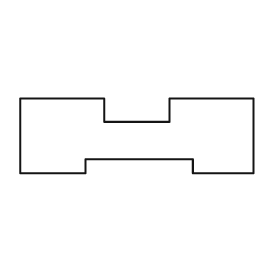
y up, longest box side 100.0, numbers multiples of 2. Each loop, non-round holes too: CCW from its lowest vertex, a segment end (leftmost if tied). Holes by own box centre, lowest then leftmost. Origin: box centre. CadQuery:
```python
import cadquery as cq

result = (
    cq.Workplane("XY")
    .moveTo(-50.0, -16.0)
    .lineTo(-22.0, -16.0)
    .lineTo(-22.0, -10.0)
    .lineTo(24.0, -10.0)
    .lineTo(24.0, -16.0)
    .lineTo(50.0, -16.0)
    .lineTo(50.0, 16.0)
    .lineTo(14.0, 16.0)
    .lineTo(14.0, 6.0)
    .lineTo(-14.0, 6.0)
    .lineTo(-14.0, 16.0)
    .lineTo(-50.0, 16.0)
    .close()
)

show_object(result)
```